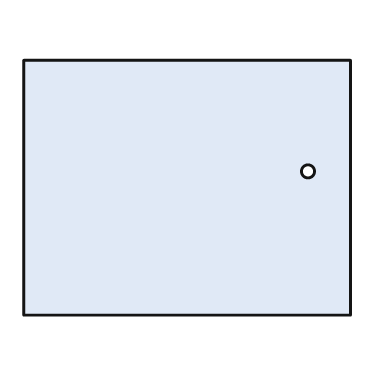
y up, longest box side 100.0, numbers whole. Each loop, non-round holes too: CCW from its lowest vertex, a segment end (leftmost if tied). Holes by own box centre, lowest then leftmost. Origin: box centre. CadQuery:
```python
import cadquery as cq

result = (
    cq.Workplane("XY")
    .moveTo(-50.0, -39.0)
    .lineTo(50.0, -39.0)
    .lineTo(50.0, 39.0)
    .lineTo(-50.0, 39.0)
    .close()
    .moveTo(37.0, 5.0)
    .circle(2.0)
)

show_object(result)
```